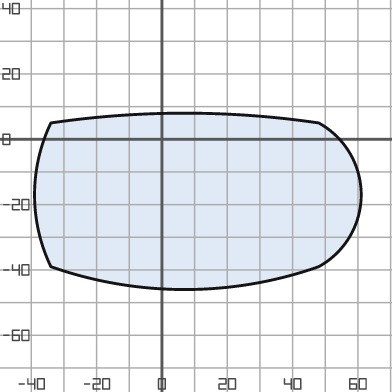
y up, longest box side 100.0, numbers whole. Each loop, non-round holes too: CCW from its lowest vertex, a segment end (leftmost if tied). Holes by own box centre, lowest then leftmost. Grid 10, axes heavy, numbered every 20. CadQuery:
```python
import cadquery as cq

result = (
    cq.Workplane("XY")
    .moveTo(-34.0, -39.0)
    .threePointArc((7.0, -46.0), (48.0, -39.0))
    .threePointArc((61.0, -17.0), (48.0, 5.0))
    .threePointArc((7.0, 8.0), (-34.0, 5.0))
    .threePointArc((-39.0, -17.0), (-34.0, -39.0))
    .close()
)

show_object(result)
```